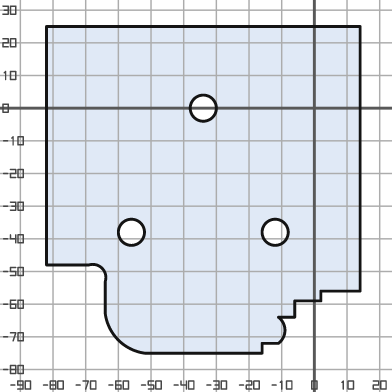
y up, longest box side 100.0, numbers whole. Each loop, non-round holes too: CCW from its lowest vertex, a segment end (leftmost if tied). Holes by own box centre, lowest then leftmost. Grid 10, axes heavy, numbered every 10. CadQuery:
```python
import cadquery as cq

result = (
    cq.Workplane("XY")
    .moveTo(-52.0, -75.0)
    .lineTo(-16.0, -75.0)
    .lineTo(-16.0, -72.0)
    .lineTo(-11.0, -72.0)
    .threePointArc((-9.0, -68.0), (-11.0, -64.0))
    .lineTo(-6.0, -64.0)
    .lineTo(-6.0, -59.0)
    .lineTo(2.0, -59.0)
    .lineTo(2.0, -56.0)
    .lineTo(14.0, -56.0)
    .lineTo(14.0, 25.0)
    .lineTo(-82.0, 25.0)
    .lineTo(-82.0, -48.0)
    .lineTo(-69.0, -48.0)
    .threePointArc((-65.0, -49.0), (-64.0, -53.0))
    .lineTo(-64.0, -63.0)
    .threePointArc((-60.0, -71.0), (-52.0, -75.0))
    .close()
    .moveTo(-56.0, -38.0)
    .circle(4.0)
    .moveTo(-12.0, -38.0)
    .circle(4.0)
    .moveTo(-34.0, 0.0)
    .circle(4.0)
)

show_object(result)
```